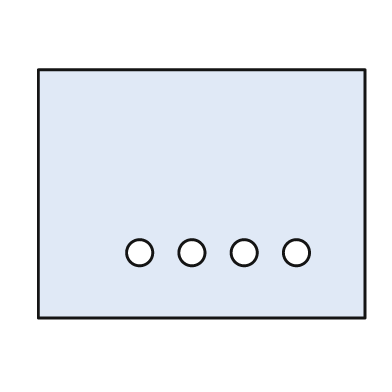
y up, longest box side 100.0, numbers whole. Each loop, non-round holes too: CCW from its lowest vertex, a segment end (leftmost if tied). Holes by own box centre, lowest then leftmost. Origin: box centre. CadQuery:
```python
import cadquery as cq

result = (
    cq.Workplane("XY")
    .moveTo(-50.0, -38.0)
    .lineTo(50.0, -38.0)
    .lineTo(50.0, 38.0)
    .lineTo(-50.0, 38.0)
    .close()
    .moveTo(-19.0, -18.0)
    .circle(4.0)
    .moveTo(-3.0, -18.0)
    .circle(4.0)
    .moveTo(13.0, -18.0)
    .circle(4.0)
    .moveTo(29.0, -18.0)
    .circle(4.0)
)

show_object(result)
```